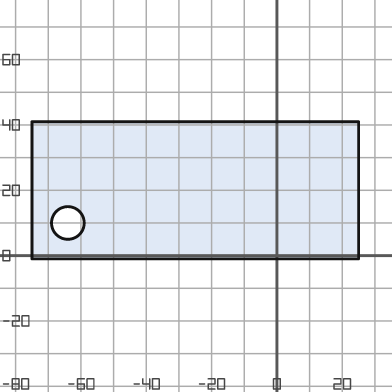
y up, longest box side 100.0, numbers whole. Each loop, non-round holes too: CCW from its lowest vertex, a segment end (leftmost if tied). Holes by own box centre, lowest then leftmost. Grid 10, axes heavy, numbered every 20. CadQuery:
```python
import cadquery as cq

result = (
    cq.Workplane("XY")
    .moveTo(-75.0, -1.0)
    .lineTo(25.0, -1.0)
    .lineTo(25.0, 41.0)
    .lineTo(-75.0, 41.0)
    .close()
    .moveTo(-64.0, 10.0)
    .circle(5.0)
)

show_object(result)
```